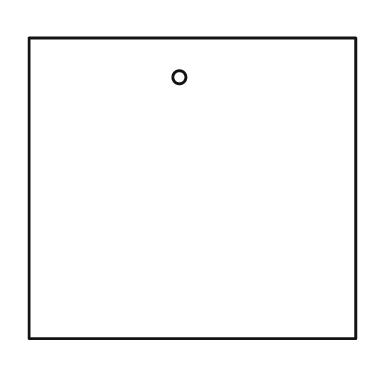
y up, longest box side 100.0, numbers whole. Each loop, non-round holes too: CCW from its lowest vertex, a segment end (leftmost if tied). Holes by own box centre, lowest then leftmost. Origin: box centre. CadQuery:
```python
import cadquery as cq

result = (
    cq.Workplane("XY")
    .moveTo(-50.0, -46.0)
    .lineTo(50.0, -46.0)
    .lineTo(50.0, 46.0)
    .lineTo(-50.0, 46.0)
    .close()
    .moveTo(-4.0, 34.0)
    .circle(2.0)
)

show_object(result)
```